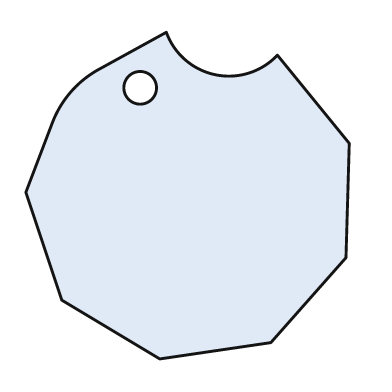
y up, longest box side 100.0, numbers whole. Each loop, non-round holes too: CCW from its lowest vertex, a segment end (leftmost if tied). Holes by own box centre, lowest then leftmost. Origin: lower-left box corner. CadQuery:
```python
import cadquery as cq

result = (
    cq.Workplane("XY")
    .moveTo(41.0, 0.0)
    .lineTo(75.0, 5.0)
    .lineTo(98.0, 31.0)
    .lineTo(99.0, 66.0)
    .lineTo(77.0, 93.0)
    .threePointArc((58.0, 87.0), (43.0, 100.0))
    .lineTo(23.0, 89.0)
    .threePointArc((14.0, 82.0), (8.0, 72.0))
    .lineTo(0.0, 51.0)
    .lineTo(11.0, 18.0)
    .close()
    .moveTo(35.0, 83.0)
    .circle(5.0)
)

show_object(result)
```